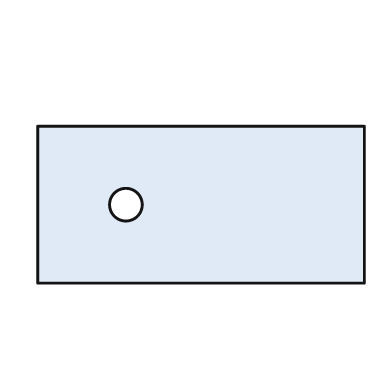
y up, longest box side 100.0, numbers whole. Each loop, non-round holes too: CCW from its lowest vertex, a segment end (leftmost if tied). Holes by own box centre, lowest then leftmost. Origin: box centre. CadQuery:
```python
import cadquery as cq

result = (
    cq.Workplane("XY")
    .moveTo(-50.0, -24.0)
    .lineTo(50.0, -24.0)
    .lineTo(50.0, 24.0)
    .lineTo(-50.0, 24.0)
    .close()
    .moveTo(-23.0, 0.0)
    .circle(5.0)
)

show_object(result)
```